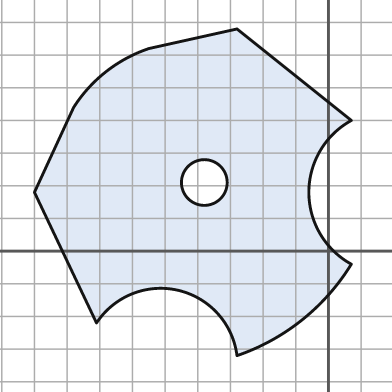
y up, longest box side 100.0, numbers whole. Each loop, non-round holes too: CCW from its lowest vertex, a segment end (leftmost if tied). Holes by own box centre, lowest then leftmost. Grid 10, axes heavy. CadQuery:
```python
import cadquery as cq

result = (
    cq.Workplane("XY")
    .moveTo(-28.0, -32.0)
    .threePointArc((-8.0, -21.0), (7.0, -4.0))
    .threePointArc((-6.0, 18.0), (7.0, 40.0))
    .lineTo(-28.0, 68.0)
    .lineTo(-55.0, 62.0)
    .threePointArc((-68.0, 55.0), (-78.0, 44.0))
    .lineTo(-90.0, 18.0)
    .lineTo(-71.0, -22.0)
    .threePointArc((-46.0, -12.0), (-28.0, -32.0))
    .close()
    .moveTo(-38.0, 21.0)
    .circle(7.0)
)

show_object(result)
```